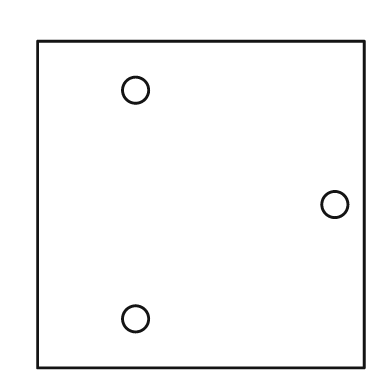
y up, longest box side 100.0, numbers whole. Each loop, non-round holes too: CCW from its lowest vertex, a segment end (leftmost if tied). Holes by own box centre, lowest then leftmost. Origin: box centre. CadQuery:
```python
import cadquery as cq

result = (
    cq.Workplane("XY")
    .moveTo(-50.0, -50.0)
    .lineTo(50.0, -50.0)
    .lineTo(50.0, 50.0)
    .lineTo(-50.0, 50.0)
    .close()
    .moveTo(-20.0, -35.0)
    .circle(4.0)
    .moveTo(41.0, 0.0)
    .circle(4.0)
    .moveTo(-20.0, 35.0)
    .circle(4.0)
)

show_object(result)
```